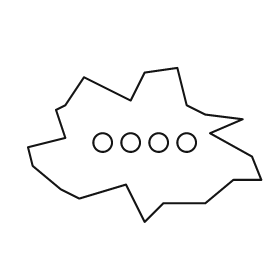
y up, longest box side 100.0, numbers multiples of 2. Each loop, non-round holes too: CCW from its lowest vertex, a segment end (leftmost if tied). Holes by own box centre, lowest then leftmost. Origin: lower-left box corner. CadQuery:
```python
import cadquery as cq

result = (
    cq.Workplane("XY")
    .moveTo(50.0, 0.0)
    .lineTo(58.0, 8.0)
    .lineTo(76.0, 8.0)
    .lineTo(88.0, 18.0)
    .lineTo(100.0, 18.0)
    .lineTo(96.0, 28.0)
    .lineTo(78.0, 38.0)
    .lineTo(92.0, 44.0)
    .lineTo(76.0, 46.0)
    .lineTo(68.0, 50.0)
    .lineTo(64.0, 66.0)
    .lineTo(50.0, 64.0)
    .lineTo(44.0, 52.0)
    .lineTo(24.0, 62.0)
    .lineTo(16.0, 50.0)
    .lineTo(12.0, 48.0)
    .lineTo(16.0, 36.0)
    .lineTo(0.0, 32.0)
    .lineTo(2.0, 24.0)
    .lineTo(14.0, 14.0)
    .lineTo(22.0, 10.0)
    .lineTo(42.0, 16.0)
    .close()
    .moveTo(32.0, 34.0)
    .circle(4.0)
    .moveTo(44.0, 34.0)
    .circle(4.0)
    .moveTo(56.0, 34.0)
    .circle(4.0)
    .moveTo(68.0, 34.0)
    .circle(4.0)
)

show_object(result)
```